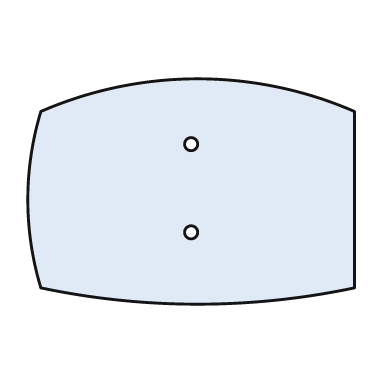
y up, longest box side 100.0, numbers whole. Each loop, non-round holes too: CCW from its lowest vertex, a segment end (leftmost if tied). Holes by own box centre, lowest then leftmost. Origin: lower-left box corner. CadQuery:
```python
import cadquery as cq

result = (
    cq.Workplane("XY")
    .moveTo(4.0, 5.0)
    .threePointArc((52.0, 0.0), (100.0, 5.0))
    .lineTo(100.0, 59.0)
    .threePointArc((52.0, 69.0), (4.0, 59.0))
    .threePointArc((0.0, 32.0), (4.0, 5.0))
    .close()
    .moveTo(50.0, 22.0)
    .circle(2.0)
    .moveTo(50.0, 49.0)
    .circle(2.0)
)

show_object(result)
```